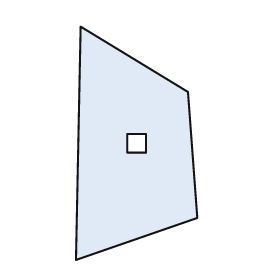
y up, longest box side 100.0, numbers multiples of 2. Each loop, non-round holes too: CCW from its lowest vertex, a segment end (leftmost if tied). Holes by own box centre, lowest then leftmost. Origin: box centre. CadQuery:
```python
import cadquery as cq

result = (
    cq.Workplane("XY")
    .moveTo(-26.0, -50.0)
    .lineTo(26.0, -32.0)
    .lineTo(22.0, 22.0)
    .lineTo(-24.0, 50.0)
    .close()
    .moveTo(-4.0, -4.0)
    .lineTo(4.0, -4.0)
    .lineTo(4.0, 4.0)
    .lineTo(-4.0, 4.0)
    .close()
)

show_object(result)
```